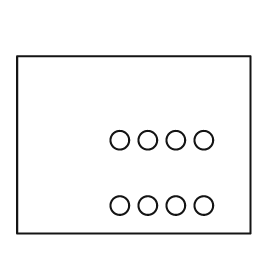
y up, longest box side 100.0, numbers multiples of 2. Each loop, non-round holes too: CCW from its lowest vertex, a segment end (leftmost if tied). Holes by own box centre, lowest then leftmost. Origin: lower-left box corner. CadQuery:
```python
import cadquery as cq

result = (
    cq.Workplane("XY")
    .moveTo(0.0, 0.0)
    .lineTo(100.0, 0.0)
    .lineTo(100.0, 76.0)
    .lineTo(0.0, 76.0)
    .close()
    .moveTo(44.0, 12.0)
    .circle(4.0)
    .moveTo(56.0, 12.0)
    .circle(4.0)
    .moveTo(68.0, 12.0)
    .circle(4.0)
    .moveTo(80.0, 12.0)
    .circle(4.0)
    .moveTo(44.0, 40.0)
    .circle(4.0)
    .moveTo(56.0, 40.0)
    .circle(4.0)
    .moveTo(68.0, 40.0)
    .circle(4.0)
    .moveTo(80.0, 40.0)
    .circle(4.0)
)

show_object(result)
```